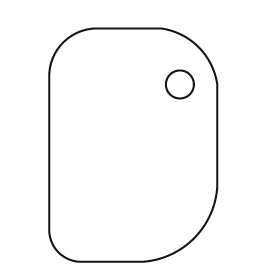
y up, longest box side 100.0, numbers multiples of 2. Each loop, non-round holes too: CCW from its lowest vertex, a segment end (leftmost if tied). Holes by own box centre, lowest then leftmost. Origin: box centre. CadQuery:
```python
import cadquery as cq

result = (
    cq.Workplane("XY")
    .moveTo(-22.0, -50.0)
    .lineTo(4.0, -50.0)
    .threePointArc((26.0, -40.0), (36.0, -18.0))
    .lineTo(36.0, 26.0)
    .threePointArc((28.0, 42.0), (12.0, 50.0))
    .lineTo(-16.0, 50.0)
    .threePointArc((-30.0, 44.0), (-36.0, 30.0))
    .lineTo(-36.0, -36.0)
    .threePointArc((-32.0, -46.0), (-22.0, -50.0))
    .close()
    .moveTo(20.0, 26.0)
    .circle(6.0)
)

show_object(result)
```